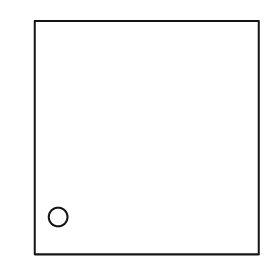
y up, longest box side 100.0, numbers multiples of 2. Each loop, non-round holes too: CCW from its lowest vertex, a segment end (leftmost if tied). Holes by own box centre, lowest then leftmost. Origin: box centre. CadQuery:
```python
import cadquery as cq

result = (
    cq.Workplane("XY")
    .moveTo(-48.0, -50.0)
    .lineTo(48.0, -50.0)
    .lineTo(48.0, 50.0)
    .lineTo(-48.0, 50.0)
    .close()
    .moveTo(-38.0, -34.0)
    .circle(4.0)
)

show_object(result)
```